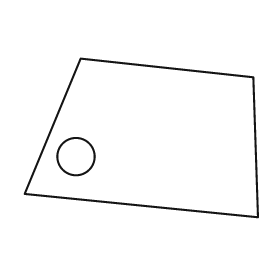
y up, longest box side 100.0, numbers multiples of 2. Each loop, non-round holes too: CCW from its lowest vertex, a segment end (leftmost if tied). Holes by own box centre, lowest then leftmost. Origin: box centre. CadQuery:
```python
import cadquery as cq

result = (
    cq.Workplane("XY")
    .moveTo(50.0, -34.0)
    .lineTo(48.0, 26.0)
    .lineTo(-26.0, 34.0)
    .lineTo(-50.0, -24.0)
    .close()
    .moveTo(-28.0, -8.0)
    .circle(8.0)
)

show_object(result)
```